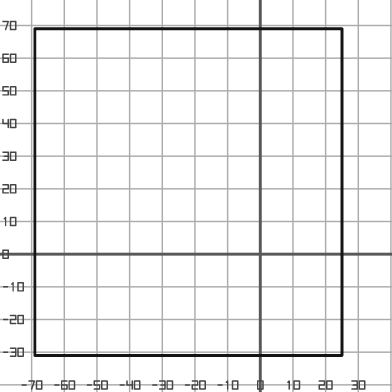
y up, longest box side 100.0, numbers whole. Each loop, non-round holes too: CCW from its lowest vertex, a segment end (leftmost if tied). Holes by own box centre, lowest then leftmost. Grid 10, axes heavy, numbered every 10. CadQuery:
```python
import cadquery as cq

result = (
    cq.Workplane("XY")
    .moveTo(-69.0, -31.0)
    .lineTo(25.0, -31.0)
    .lineTo(25.0, 69.0)
    .lineTo(-69.0, 69.0)
    .close()
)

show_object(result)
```